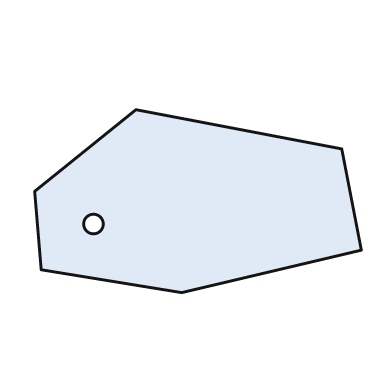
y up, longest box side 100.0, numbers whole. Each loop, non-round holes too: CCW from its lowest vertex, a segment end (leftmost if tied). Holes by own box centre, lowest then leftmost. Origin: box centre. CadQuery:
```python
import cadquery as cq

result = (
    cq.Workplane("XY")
    .moveTo(-5.0, -28.0)
    .lineTo(50.0, -15.0)
    .lineTo(44.0, 16.0)
    .lineTo(-19.0, 28.0)
    .lineTo(-50.0, 3.0)
    .lineTo(-48.0, -21.0)
    .close()
    .moveTo(-32.0, -7.0)
    .circle(3.0)
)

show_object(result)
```